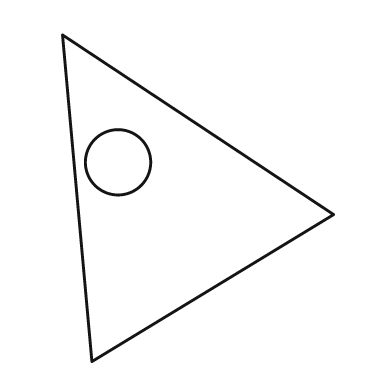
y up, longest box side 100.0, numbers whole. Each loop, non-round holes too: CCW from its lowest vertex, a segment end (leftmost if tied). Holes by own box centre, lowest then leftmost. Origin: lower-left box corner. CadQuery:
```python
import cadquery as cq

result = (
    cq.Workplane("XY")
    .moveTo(9.0, 0.0)
    .lineTo(83.0, 45.0)
    .lineTo(0.0, 100.0)
    .close()
    .moveTo(17.0, 61.0)
    .circle(10.0)
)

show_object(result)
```